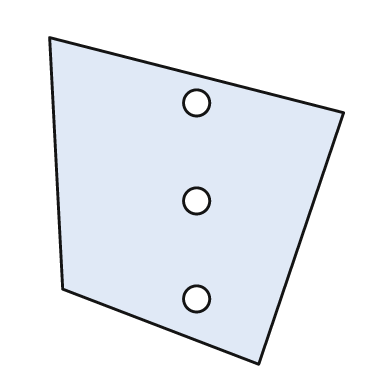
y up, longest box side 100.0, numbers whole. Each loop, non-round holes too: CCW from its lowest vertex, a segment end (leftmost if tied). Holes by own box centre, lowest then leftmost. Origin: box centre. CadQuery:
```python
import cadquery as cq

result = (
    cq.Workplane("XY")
    .moveTo(19.0, -50.0)
    .lineTo(45.0, 27.0)
    .lineTo(-45.0, 50.0)
    .lineTo(-41.0, -27.0)
    .close()
    .moveTo(0.0, -30.0)
    .circle(4.0)
    .moveTo(0.0, 0.0)
    .circle(4.0)
    .moveTo(0.0, 30.0)
    .circle(4.0)
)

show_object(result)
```